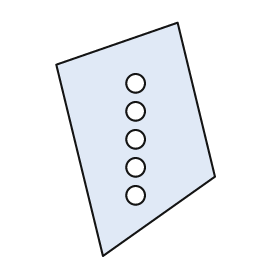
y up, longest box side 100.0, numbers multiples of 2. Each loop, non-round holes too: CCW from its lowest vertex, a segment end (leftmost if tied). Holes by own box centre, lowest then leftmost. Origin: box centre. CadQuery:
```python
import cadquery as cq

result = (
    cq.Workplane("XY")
    .moveTo(-14.0, -50.0)
    .lineTo(34.0, -16.0)
    .lineTo(18.0, 50.0)
    .lineTo(-34.0, 32.0)
    .close()
    .moveTo(0.0, -24.0)
    .circle(4.0)
    .moveTo(0.0, -12.0)
    .circle(4.0)
    .moveTo(0.0, 0.0)
    .circle(4.0)
    .moveTo(0.0, 12.0)
    .circle(4.0)
    .moveTo(0.0, 24.0)
    .circle(4.0)
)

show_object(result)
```